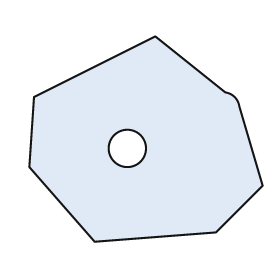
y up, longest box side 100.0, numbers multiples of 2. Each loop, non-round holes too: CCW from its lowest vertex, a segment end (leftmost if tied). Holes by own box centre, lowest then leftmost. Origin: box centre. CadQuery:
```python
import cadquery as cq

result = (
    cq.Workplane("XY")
    .moveTo(-22.0, -44.0)
    .lineTo(30.0, -40.0)
    .lineTo(50.0, -20.0)
    .lineTo(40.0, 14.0)
    .threePointArc((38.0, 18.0), (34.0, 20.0))
    .lineTo(4.0, 44.0)
    .lineTo(-48.0, 18.0)
    .lineTo(-50.0, -12.0)
    .close()
    .moveTo(-8.0, -4.0)
    .circle(8.0)
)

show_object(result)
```